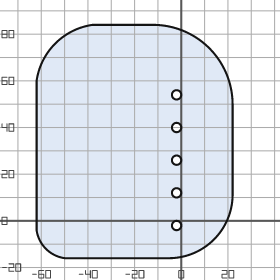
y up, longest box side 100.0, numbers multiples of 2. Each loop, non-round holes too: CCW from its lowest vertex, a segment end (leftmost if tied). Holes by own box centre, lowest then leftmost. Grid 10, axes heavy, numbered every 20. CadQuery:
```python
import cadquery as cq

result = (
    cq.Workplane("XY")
    .moveTo(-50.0, -16.0)
    .lineTo(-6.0, -16.0)
    .threePointArc((14.0, -8.0), (22.0, 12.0))
    .lineTo(22.0, 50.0)
    .threePointArc((12.0, 74.0), (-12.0, 84.0))
    .lineTo(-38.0, 84.0)
    .threePointArc((-54.0, 76.0), (-62.0, 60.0))
    .lineTo(-62.0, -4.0)
    .threePointArc((-58.0, -12.0), (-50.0, -16.0))
    .close()
    .moveTo(-2.0, -2.0)
    .circle(2.0)
    .moveTo(-2.0, 12.0)
    .circle(2.0)
    .moveTo(-2.0, 26.0)
    .circle(2.0)
    .moveTo(-2.0, 40.0)
    .circle(2.0)
    .moveTo(-2.0, 54.0)
    .circle(2.0)
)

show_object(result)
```